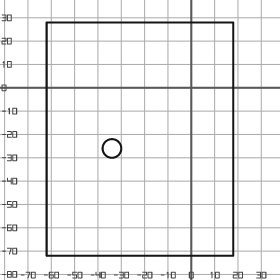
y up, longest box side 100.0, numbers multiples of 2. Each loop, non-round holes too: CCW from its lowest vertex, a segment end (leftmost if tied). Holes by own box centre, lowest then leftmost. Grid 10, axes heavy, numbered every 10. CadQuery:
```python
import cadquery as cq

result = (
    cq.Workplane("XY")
    .moveTo(-62.0, -72.0)
    .lineTo(18.0, -72.0)
    .lineTo(18.0, 28.0)
    .lineTo(-62.0, 28.0)
    .close()
    .moveTo(-34.0, -26.0)
    .circle(4.0)
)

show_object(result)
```